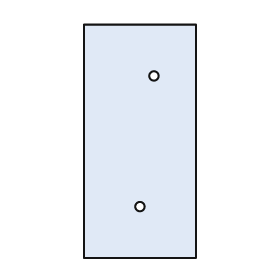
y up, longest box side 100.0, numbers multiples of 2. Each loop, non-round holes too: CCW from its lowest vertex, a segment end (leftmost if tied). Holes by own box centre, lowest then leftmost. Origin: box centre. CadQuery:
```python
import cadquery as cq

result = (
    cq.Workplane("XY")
    .moveTo(-24.0, -50.0)
    .lineTo(24.0, -50.0)
    .lineTo(24.0, 50.0)
    .lineTo(-24.0, 50.0)
    .close()
    .moveTo(0.0, -28.0)
    .circle(2.0)
    .moveTo(6.0, 28.0)
    .circle(2.0)
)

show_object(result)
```